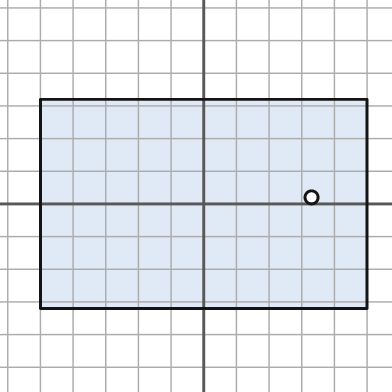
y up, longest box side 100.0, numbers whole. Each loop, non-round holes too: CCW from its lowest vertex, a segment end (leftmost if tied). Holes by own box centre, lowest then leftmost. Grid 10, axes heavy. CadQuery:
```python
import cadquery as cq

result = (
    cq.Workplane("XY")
    .moveTo(-50.0, -32.0)
    .lineTo(50.0, -32.0)
    .lineTo(50.0, 32.0)
    .lineTo(-50.0, 32.0)
    .close()
    .moveTo(33.0, 2.0)
    .circle(2.0)
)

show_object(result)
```